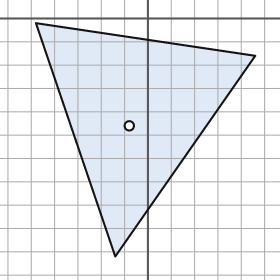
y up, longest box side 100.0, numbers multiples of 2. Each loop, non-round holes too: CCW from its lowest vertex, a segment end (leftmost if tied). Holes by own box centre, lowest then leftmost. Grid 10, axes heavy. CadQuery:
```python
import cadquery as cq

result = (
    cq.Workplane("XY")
    .moveTo(-14.0, -102.0)
    .lineTo(46.0, -16.0)
    .lineTo(-48.0, -2.0)
    .close()
    .moveTo(-8.0, -46.0)
    .circle(2.0)
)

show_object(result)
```